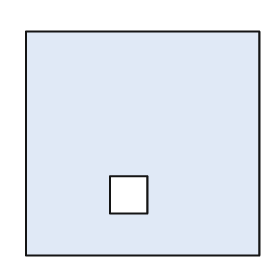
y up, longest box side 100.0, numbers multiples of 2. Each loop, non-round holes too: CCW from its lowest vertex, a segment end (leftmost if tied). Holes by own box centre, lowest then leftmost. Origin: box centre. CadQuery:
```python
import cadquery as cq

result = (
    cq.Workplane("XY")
    .moveTo(-50.0, -48.0)
    .lineTo(50.0, -48.0)
    .lineTo(50.0, 48.0)
    .lineTo(-50.0, 48.0)
    .close()
    .moveTo(-14.0, -30.0)
    .lineTo(2.0, -30.0)
    .lineTo(2.0, -14.0)
    .lineTo(-14.0, -14.0)
    .close()
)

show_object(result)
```